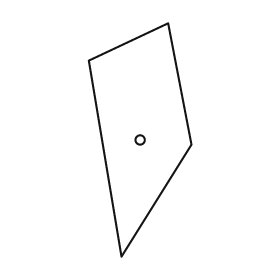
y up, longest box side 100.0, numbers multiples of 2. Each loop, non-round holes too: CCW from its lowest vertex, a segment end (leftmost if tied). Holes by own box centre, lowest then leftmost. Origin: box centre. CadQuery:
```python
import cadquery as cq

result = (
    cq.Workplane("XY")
    .moveTo(-8.0, -50.0)
    .lineTo(22.0, -2.0)
    .lineTo(12.0, 50.0)
    .lineTo(-22.0, 34.0)
    .close()
    .moveTo(0.0, 0.0)
    .circle(2.0)
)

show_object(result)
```